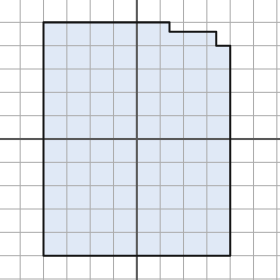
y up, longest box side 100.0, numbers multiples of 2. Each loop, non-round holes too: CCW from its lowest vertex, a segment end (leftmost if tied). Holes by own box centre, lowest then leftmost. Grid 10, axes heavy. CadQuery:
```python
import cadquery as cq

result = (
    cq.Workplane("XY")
    .moveTo(-40.0, -50.0)
    .lineTo(40.0, -50.0)
    .lineTo(40.0, 40.0)
    .lineTo(34.0, 40.0)
    .lineTo(34.0, 46.0)
    .lineTo(14.0, 46.0)
    .lineTo(14.0, 50.0)
    .lineTo(-40.0, 50.0)
    .close()
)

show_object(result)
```